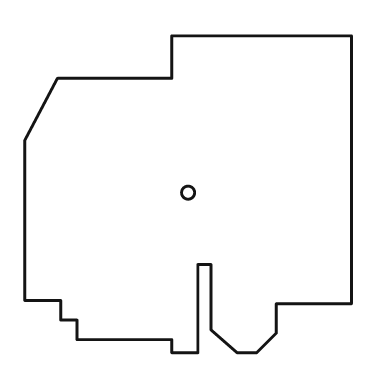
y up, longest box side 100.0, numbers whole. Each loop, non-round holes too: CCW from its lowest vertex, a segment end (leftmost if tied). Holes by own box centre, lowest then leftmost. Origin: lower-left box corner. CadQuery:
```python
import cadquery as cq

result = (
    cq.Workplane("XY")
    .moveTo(45.0, 0.0)
    .lineTo(53.0, 0.0)
    .lineTo(53.0, 27.0)
    .lineTo(57.0, 27.0)
    .lineTo(57.0, 7.0)
    .lineTo(65.0, 0.0)
    .lineTo(71.0, 0.0)
    .lineTo(77.0, 6.0)
    .lineTo(77.0, 15.0)
    .lineTo(100.0, 15.0)
    .lineTo(100.0, 97.0)
    .lineTo(45.0, 97.0)
    .lineTo(45.0, 84.0)
    .lineTo(10.0, 84.0)
    .lineTo(0.0, 65.0)
    .lineTo(0.0, 16.0)
    .lineTo(11.0, 16.0)
    .lineTo(11.0, 10.0)
    .lineTo(16.0, 10.0)
    .lineTo(16.0, 4.0)
    .lineTo(45.0, 4.0)
    .close()
    .moveTo(50.0, 49.0)
    .circle(2.0)
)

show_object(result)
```